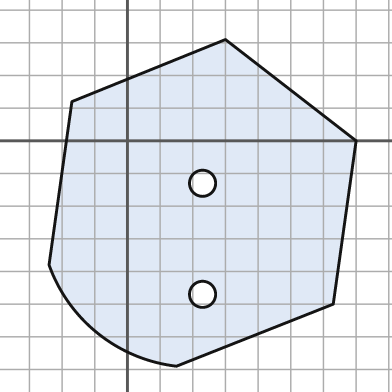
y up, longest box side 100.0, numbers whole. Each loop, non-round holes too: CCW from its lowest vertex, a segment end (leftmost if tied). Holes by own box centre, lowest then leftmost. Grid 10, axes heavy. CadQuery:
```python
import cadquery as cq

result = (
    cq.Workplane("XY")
    .moveTo(15.0, -69.0)
    .lineTo(63.0, -50.0)
    .lineTo(70.0, 0.0)
    .lineTo(30.0, 31.0)
    .lineTo(-17.0, 12.0)
    .lineTo(-24.0, -38.0)
    .threePointArc((-9.0, -59.0), (15.0, -69.0))
    .close()
    .moveTo(23.0, -47.0)
    .circle(4.0)
    .moveTo(23.0, -13.0)
    .circle(4.0)
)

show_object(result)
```